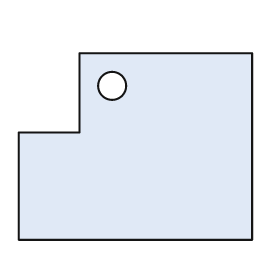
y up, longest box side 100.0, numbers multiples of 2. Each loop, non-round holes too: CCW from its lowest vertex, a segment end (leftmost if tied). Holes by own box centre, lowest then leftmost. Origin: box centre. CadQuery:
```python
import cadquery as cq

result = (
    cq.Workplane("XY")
    .moveTo(-50.0, -40.0)
    .lineTo(50.0, -40.0)
    .lineTo(50.0, 40.0)
    .lineTo(-24.0, 40.0)
    .lineTo(-24.0, 6.0)
    .lineTo(-50.0, 6.0)
    .close()
    .moveTo(-10.0, 26.0)
    .circle(6.0)
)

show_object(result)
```